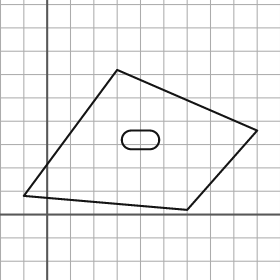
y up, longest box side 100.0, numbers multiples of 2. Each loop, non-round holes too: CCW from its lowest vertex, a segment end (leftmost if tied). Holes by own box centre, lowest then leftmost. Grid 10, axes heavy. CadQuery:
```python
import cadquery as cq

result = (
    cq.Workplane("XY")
    .moveTo(60.0, 2.0)
    .lineTo(90.0, 36.0)
    .lineTo(30.0, 62.0)
    .lineTo(-10.0, 8.0)
    .close()
    .moveTo(36.0, 28.0)
    .lineTo(44.0, 28.0)
    .threePointArc((48.0, 32.0), (44.0, 36.0))
    .lineTo(36.0, 36.0)
    .threePointArc((32.0, 32.0), (36.0, 28.0))
    .close()
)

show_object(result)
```